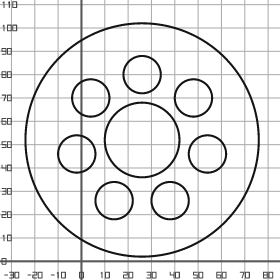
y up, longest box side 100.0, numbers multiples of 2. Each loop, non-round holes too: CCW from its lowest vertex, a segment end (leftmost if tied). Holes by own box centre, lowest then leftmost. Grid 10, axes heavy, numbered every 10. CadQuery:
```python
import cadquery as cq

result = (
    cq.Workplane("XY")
    .moveTo(26.0, 52.0)
    .circle(50.0)
    .moveTo(14.0, 26.0)
    .circle(8.0)
    .moveTo(38.0, 26.0)
    .circle(8.0)
    .moveTo(-2.0, 46.0)
    .circle(8.0)
    .moveTo(54.0, 46.0)
    .circle(8.0)
    .moveTo(26.0, 52.0)
    .circle(16.0)
    .moveTo(4.0, 70.0)
    .circle(8.0)
    .moveTo(48.0, 70.0)
    .circle(8.0)
    .moveTo(26.0, 80.0)
    .circle(8.0)
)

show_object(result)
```